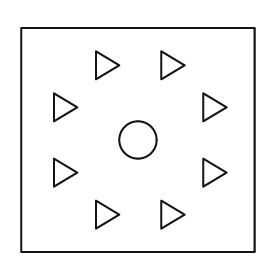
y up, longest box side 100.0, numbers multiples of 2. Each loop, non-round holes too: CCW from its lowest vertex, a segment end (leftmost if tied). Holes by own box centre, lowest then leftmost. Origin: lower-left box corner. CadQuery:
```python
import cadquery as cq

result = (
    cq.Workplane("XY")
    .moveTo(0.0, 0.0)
    .lineTo(100.0, 0.0)
    .lineTo(100.0, 96.0)
    .lineTo(0.0, 96.0)
    .close()
    .moveTo(32.0, 10.0)
    .lineTo(42.0, 16.0)
    .lineTo(32.0, 22.0)
    .close()
    .moveTo(60.0, 10.0)
    .lineTo(70.0, 16.0)
    .lineTo(60.0, 22.0)
    .close()
    .moveTo(14.0, 28.0)
    .lineTo(24.0, 34.0)
    .lineTo(14.0, 40.0)
    .close()
    .moveTo(78.0, 28.0)
    .lineTo(88.0, 34.0)
    .lineTo(78.0, 40.0)
    .close()
    .moveTo(50.0, 48.0)
    .circle(8.0)
    .moveTo(14.0, 56.0)
    .lineTo(24.0, 62.0)
    .lineTo(14.0, 68.0)
    .close()
    .moveTo(78.0, 56.0)
    .lineTo(88.0, 62.0)
    .lineTo(78.0, 68.0)
    .close()
    .moveTo(32.0, 74.0)
    .lineTo(42.0, 80.0)
    .lineTo(32.0, 86.0)
    .close()
    .moveTo(60.0, 74.0)
    .lineTo(70.0, 80.0)
    .lineTo(60.0, 86.0)
    .close()
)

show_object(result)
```